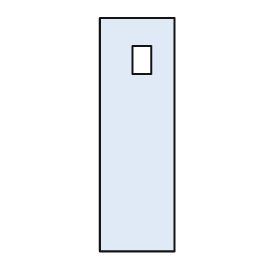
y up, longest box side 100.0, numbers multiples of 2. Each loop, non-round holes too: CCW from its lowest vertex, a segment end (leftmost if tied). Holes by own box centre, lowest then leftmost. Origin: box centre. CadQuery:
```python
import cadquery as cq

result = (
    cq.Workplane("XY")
    .moveTo(-16.0, -50.0)
    .lineTo(16.0, -50.0)
    .lineTo(16.0, 50.0)
    .lineTo(-16.0, 50.0)
    .close()
    .moveTo(-2.0, 26.0)
    .lineTo(6.0, 26.0)
    .lineTo(6.0, 38.0)
    .lineTo(-2.0, 38.0)
    .close()
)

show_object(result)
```